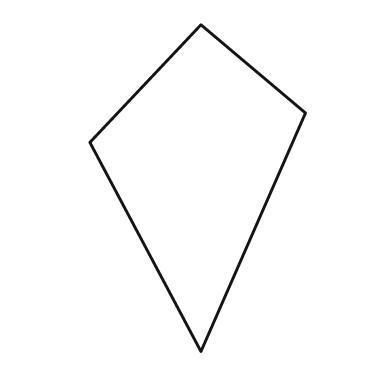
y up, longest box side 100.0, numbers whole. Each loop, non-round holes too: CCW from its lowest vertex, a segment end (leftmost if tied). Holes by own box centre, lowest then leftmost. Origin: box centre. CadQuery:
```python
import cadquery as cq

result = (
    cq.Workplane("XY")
    .moveTo(1.0, -50.0)
    .lineTo(33.0, 23.0)
    .lineTo(1.0, 50.0)
    .lineTo(-33.0, 14.0)
    .close()
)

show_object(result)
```